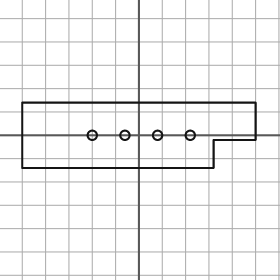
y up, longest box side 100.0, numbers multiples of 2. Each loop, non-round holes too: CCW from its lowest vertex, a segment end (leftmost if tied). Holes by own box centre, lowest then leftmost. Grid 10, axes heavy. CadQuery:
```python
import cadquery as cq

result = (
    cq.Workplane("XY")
    .moveTo(-50.0, -14.0)
    .lineTo(32.0, -14.0)
    .lineTo(32.0, -2.0)
    .lineTo(50.0, -2.0)
    .lineTo(50.0, 14.0)
    .lineTo(-50.0, 14.0)
    .close()
    .moveTo(-20.0, 0.0)
    .circle(2.0)
    .moveTo(-6.0, 0.0)
    .circle(2.0)
    .moveTo(8.0, 0.0)
    .circle(2.0)
    .moveTo(22.0, 0.0)
    .circle(2.0)
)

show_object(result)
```